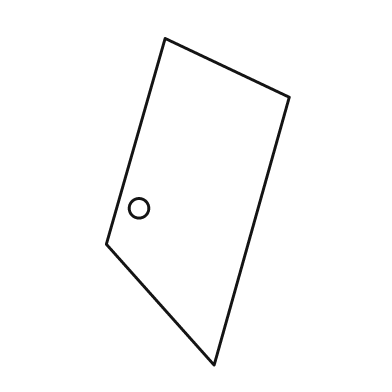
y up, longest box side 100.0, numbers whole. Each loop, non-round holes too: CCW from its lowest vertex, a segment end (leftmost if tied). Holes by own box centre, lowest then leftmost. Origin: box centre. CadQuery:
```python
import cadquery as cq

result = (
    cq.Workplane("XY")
    .moveTo(5.0, -50.0)
    .lineTo(28.0, 32.0)
    .lineTo(-10.0, 50.0)
    .lineTo(-28.0, -13.0)
    .close()
    .moveTo(-18.0, -2.0)
    .circle(3.0)
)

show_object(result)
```